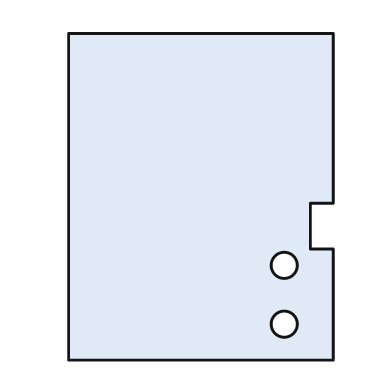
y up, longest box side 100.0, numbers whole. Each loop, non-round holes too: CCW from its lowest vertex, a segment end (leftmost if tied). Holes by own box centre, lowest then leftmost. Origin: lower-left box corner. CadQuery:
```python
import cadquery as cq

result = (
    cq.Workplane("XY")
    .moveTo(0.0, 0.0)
    .lineTo(81.0, 0.0)
    .lineTo(81.0, 34.0)
    .lineTo(74.0, 34.0)
    .lineTo(74.0, 48.0)
    .lineTo(81.0, 48.0)
    .lineTo(81.0, 100.0)
    .lineTo(0.0, 100.0)
    .close()
    .moveTo(66.0, 11.0)
    .circle(4.0)
    .moveTo(66.0, 29.0)
    .circle(4.0)
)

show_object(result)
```